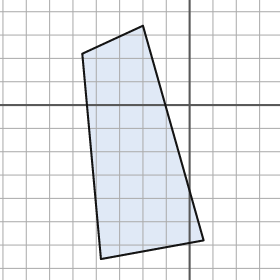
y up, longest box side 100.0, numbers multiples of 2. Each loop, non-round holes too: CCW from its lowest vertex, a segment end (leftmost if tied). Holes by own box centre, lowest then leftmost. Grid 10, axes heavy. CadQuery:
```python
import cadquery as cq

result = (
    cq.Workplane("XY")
    .moveTo(-38.0, -66.0)
    .lineTo(6.0, -58.0)
    .lineTo(-20.0, 34.0)
    .lineTo(-46.0, 22.0)
    .close()
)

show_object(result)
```